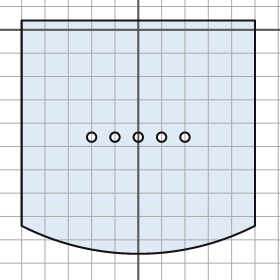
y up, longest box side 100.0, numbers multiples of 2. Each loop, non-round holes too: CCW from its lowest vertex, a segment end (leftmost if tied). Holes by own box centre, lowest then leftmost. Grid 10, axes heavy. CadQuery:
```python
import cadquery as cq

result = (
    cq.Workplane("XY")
    .moveTo(-50.0, -84.0)
    .threePointArc((0.0, -96.0), (50.0, -84.0))
    .lineTo(50.0, 4.0)
    .lineTo(-50.0, 4.0)
    .close()
    .moveTo(-20.0, -46.0)
    .circle(2.0)
    .moveTo(-10.0, -46.0)
    .circle(2.0)
    .moveTo(0.0, -46.0)
    .circle(2.0)
    .moveTo(10.0, -46.0)
    .circle(2.0)
    .moveTo(20.0, -46.0)
    .circle(2.0)
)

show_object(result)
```